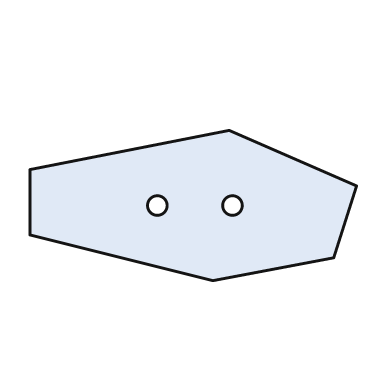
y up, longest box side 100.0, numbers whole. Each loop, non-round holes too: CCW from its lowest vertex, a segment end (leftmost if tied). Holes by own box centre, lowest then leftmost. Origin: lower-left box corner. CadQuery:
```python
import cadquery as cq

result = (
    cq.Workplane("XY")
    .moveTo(56.0, 0.0)
    .lineTo(93.0, 7.0)
    .lineTo(100.0, 29.0)
    .lineTo(61.0, 46.0)
    .lineTo(0.0, 34.0)
    .lineTo(0.0, 14.0)
    .close()
    .moveTo(39.0, 23.0)
    .circle(3.0)
    .moveTo(62.0, 23.0)
    .circle(3.0)
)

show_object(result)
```